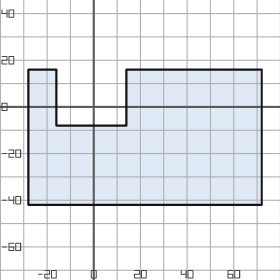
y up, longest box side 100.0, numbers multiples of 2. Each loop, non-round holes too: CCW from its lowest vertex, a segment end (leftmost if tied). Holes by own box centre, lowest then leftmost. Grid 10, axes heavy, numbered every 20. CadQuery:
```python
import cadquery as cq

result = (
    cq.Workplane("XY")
    .moveTo(-28.0, -42.0)
    .lineTo(72.0, -42.0)
    .lineTo(72.0, 16.0)
    .lineTo(14.0, 16.0)
    .lineTo(14.0, -8.0)
    .lineTo(-16.0, -8.0)
    .lineTo(-16.0, 16.0)
    .lineTo(-28.0, 16.0)
    .close()
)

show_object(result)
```